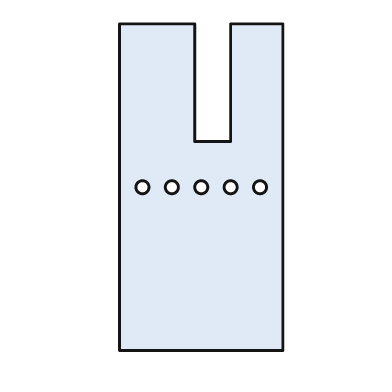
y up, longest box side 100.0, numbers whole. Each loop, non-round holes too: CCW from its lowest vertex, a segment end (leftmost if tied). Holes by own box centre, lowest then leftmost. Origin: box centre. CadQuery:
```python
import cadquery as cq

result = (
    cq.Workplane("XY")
    .moveTo(-25.0, -50.0)
    .lineTo(25.0, -50.0)
    .lineTo(25.0, 50.0)
    .lineTo(9.0, 50.0)
    .lineTo(9.0, 14.0)
    .lineTo(-2.0, 14.0)
    .lineTo(-2.0, 50.0)
    .lineTo(-25.0, 50.0)
    .close()
    .moveTo(-18.0, 0.0)
    .circle(2.0)
    .moveTo(-9.0, 0.0)
    .circle(2.0)
    .moveTo(0.0, 0.0)
    .circle(2.0)
    .moveTo(9.0, 0.0)
    .circle(2.0)
    .moveTo(18.0, 0.0)
    .circle(2.0)
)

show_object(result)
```